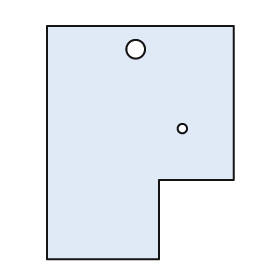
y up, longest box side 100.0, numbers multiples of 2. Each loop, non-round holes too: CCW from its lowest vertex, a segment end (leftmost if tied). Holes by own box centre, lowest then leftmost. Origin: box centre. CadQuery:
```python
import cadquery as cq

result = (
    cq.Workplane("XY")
    .moveTo(-40.0, -50.0)
    .lineTo(8.0, -50.0)
    .lineTo(8.0, -16.0)
    .lineTo(40.0, -16.0)
    .lineTo(40.0, 50.0)
    .lineTo(-40.0, 50.0)
    .close()
    .moveTo(18.0, 6.0)
    .circle(2.0)
    .moveTo(-2.0, 40.0)
    .circle(4.0)
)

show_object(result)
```